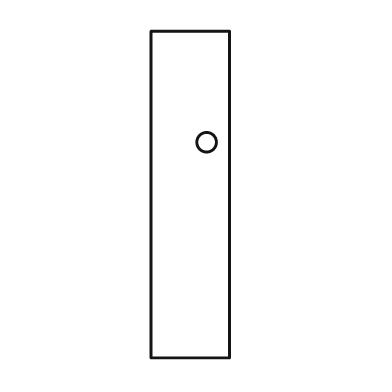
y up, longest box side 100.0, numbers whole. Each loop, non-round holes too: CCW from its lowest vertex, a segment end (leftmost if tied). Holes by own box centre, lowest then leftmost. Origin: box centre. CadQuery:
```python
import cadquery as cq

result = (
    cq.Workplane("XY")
    .moveTo(-12.0, -50.0)
    .lineTo(12.0, -50.0)
    .lineTo(12.0, 50.0)
    .lineTo(-12.0, 50.0)
    .close()
    .moveTo(5.0, 16.0)
    .circle(3.0)
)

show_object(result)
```